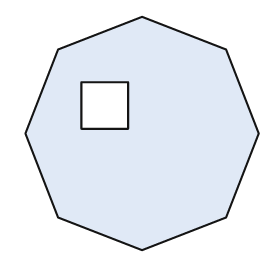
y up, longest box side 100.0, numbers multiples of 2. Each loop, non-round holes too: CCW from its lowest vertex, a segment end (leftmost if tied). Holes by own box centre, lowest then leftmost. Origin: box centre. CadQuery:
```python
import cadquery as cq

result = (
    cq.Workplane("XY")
    .moveTo(0.0, -50.0)
    .lineTo(36.0, -36.0)
    .lineTo(50.0, 0.0)
    .lineTo(36.0, 36.0)
    .lineTo(0.0, 50.0)
    .lineTo(-36.0, 36.0)
    .lineTo(-50.0, 0.0)
    .lineTo(-36.0, -36.0)
    .close()
    .moveTo(-26.0, 2.0)
    .lineTo(-6.0, 2.0)
    .lineTo(-6.0, 22.0)
    .lineTo(-26.0, 22.0)
    .close()
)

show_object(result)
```